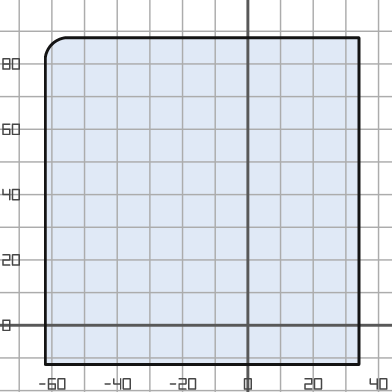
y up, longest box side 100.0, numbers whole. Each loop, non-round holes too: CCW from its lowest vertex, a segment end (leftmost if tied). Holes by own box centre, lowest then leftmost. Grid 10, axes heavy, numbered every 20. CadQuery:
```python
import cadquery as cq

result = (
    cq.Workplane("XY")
    .moveTo(-62.0, -12.0)
    .lineTo(34.0, -12.0)
    .lineTo(34.0, 88.0)
    .lineTo(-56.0, 88.0)
    .threePointArc((-60.0, 86.0), (-62.0, 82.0))
    .close()
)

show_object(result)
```